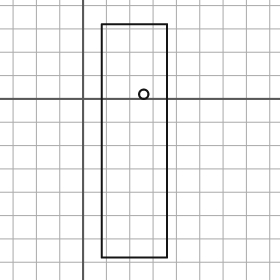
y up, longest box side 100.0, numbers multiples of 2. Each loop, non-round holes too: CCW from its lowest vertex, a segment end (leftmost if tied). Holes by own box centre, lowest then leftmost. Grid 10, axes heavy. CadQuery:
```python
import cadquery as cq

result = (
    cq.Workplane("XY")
    .moveTo(8.0, -68.0)
    .lineTo(36.0, -68.0)
    .lineTo(36.0, 32.0)
    .lineTo(8.0, 32.0)
    .close()
    .moveTo(26.0, 2.0)
    .circle(2.0)
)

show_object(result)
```